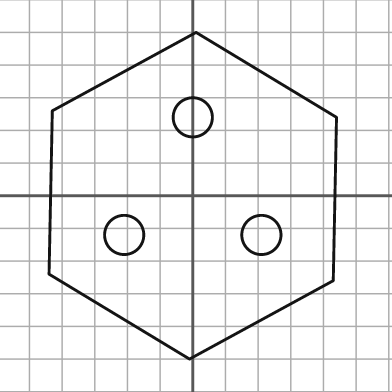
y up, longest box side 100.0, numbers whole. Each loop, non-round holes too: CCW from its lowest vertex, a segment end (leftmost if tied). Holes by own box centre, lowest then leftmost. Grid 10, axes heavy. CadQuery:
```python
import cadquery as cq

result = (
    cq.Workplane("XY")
    .moveTo(-1.0, -50.0)
    .lineTo(43.0, -26.0)
    .lineTo(44.0, 24.0)
    .lineTo(1.0, 50.0)
    .lineTo(-43.0, 26.0)
    .lineTo(-44.0, -24.0)
    .close()
    .moveTo(-21.0, -12.0)
    .circle(6.0)
    .moveTo(21.0, -12.0)
    .circle(6.0)
    .moveTo(0.0, 24.0)
    .circle(6.0)
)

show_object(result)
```